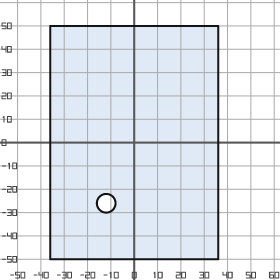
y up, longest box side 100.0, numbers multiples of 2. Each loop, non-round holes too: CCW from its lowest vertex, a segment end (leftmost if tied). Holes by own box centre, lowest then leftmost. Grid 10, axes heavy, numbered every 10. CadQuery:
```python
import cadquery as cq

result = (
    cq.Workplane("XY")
    .moveTo(-36.0, -50.0)
    .lineTo(36.0, -50.0)
    .lineTo(36.0, 50.0)
    .lineTo(-36.0, 50.0)
    .close()
    .moveTo(-12.0, -26.0)
    .circle(4.0)
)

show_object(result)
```